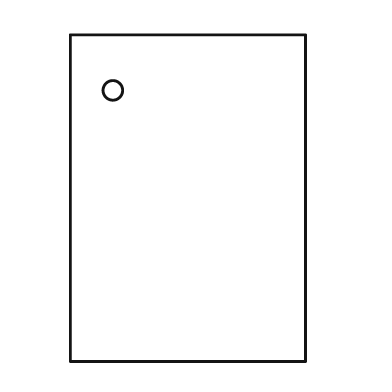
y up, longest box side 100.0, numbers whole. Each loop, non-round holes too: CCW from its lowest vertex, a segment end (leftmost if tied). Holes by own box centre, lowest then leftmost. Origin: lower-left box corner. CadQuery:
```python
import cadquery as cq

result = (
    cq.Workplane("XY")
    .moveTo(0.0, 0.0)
    .lineTo(72.0, 0.0)
    .lineTo(72.0, 100.0)
    .lineTo(0.0, 100.0)
    .close()
    .moveTo(13.0, 83.0)
    .circle(3.0)
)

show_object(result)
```